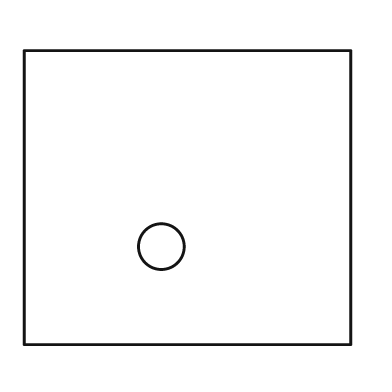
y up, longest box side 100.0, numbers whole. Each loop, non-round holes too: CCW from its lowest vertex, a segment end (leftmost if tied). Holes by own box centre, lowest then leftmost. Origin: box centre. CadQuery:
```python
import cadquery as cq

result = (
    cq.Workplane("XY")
    .moveTo(-50.0, -45.0)
    .lineTo(50.0, -45.0)
    .lineTo(50.0, 45.0)
    .lineTo(-50.0, 45.0)
    .close()
    .moveTo(-8.0, -15.0)
    .circle(7.0)
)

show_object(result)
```